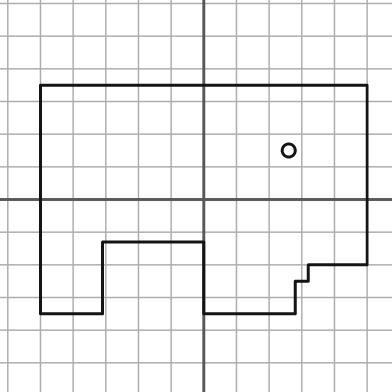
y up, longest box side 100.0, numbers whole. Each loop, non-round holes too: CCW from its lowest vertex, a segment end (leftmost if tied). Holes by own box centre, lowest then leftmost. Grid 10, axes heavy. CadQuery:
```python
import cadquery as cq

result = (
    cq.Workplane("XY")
    .moveTo(-50.0, -35.0)
    .lineTo(-31.0, -35.0)
    .lineTo(-31.0, -13.0)
    .lineTo(0.0, -13.0)
    .lineTo(0.0, -35.0)
    .lineTo(28.0, -35.0)
    .lineTo(28.0, -25.0)
    .lineTo(32.0, -25.0)
    .lineTo(32.0, -20.0)
    .lineTo(50.0, -20.0)
    .lineTo(50.0, 35.0)
    .lineTo(-50.0, 35.0)
    .close()
    .moveTo(26.0, 15.0)
    .circle(2.0)
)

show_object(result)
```